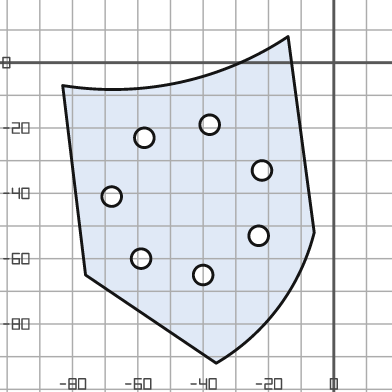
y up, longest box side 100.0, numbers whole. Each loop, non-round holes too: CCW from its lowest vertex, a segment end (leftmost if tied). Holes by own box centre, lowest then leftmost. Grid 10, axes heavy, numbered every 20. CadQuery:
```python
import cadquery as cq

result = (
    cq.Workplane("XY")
    .moveTo(-36.0, -92.0)
    .threePointArc((-17.0, -75.0), (-6.0, -52.0))
    .lineTo(-14.0, 8.0)
    .threePointArc((-47.0, -6.0), (-83.0, -7.0))
    .lineTo(-76.0, -65.0)
    .close()
    .moveTo(-40.0, -65.0)
    .circle(3.0)
    .moveTo(-59.0, -60.0)
    .circle(3.0)
    .moveTo(-23.0, -53.0)
    .circle(3.0)
    .moveTo(-68.0, -41.0)
    .circle(3.0)
    .moveTo(-22.0, -33.0)
    .circle(3.0)
    .moveTo(-58.0, -23.0)
    .circle(3.0)
    .moveTo(-38.0, -19.0)
    .circle(3.0)
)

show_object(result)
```